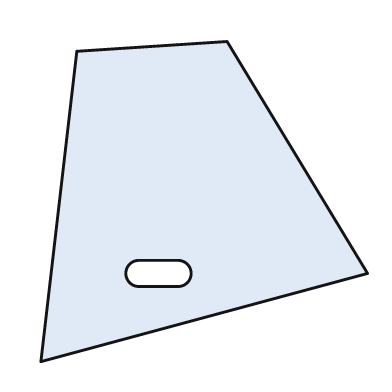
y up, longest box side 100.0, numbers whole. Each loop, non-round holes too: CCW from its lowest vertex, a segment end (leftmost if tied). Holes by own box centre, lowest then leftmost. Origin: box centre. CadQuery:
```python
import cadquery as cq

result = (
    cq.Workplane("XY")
    .moveTo(-50.0, -49.0)
    .lineTo(50.0, -22.0)
    .lineTo(7.0, 49.0)
    .lineTo(-39.0, 46.0)
    .close()
    .moveTo(-20.0, -26.0)
    .lineTo(-8.0, -26.0)
    .threePointArc((-4.0, -22.0), (-8.0, -18.0))
    .lineTo(-20.0, -18.0)
    .threePointArc((-24.0, -22.0), (-20.0, -26.0))
    .close()
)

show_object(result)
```